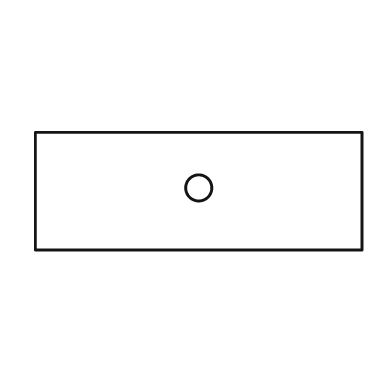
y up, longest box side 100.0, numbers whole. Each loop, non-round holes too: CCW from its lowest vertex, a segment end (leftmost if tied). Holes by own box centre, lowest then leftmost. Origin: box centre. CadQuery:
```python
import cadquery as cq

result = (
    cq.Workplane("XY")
    .moveTo(-50.0, -18.0)
    .lineTo(50.0, -18.0)
    .lineTo(50.0, 18.0)
    .lineTo(-50.0, 18.0)
    .close()
    .moveTo(0.0, 1.0)
    .circle(4.0)
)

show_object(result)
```